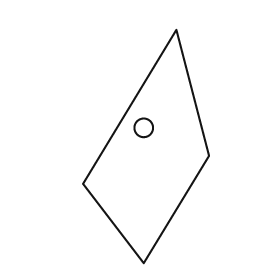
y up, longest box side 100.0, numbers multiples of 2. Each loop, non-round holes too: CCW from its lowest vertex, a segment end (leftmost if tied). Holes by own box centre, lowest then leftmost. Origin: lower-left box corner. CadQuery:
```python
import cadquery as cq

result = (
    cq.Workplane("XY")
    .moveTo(26.0, 0.0)
    .lineTo(54.0, 46.0)
    .lineTo(40.0, 100.0)
    .lineTo(0.0, 34.0)
    .close()
    .moveTo(26.0, 58.0)
    .circle(4.0)
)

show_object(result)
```